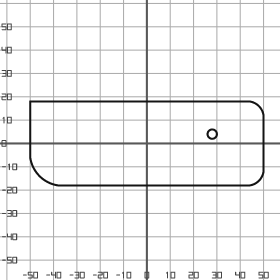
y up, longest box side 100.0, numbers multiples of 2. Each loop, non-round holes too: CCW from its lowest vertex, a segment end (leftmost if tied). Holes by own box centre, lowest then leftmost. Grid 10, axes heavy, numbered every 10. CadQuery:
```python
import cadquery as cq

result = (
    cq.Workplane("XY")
    .moveTo(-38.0, -18.0)
    .lineTo(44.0, -18.0)
    .threePointArc((48.0, -16.0), (50.0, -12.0))
    .lineTo(50.0, 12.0)
    .threePointArc((48.0, 16.0), (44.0, 18.0))
    .lineTo(-50.0, 18.0)
    .lineTo(-50.0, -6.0)
    .threePointArc((-46.0, -14.0), (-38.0, -18.0))
    .close()
    .moveTo(28.0, 4.0)
    .circle(2.0)
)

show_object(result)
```